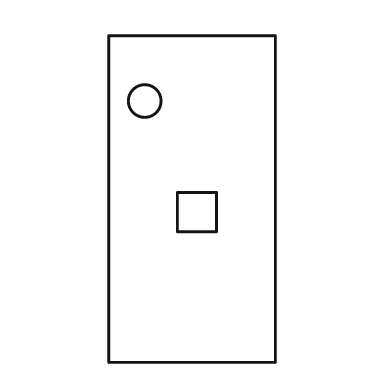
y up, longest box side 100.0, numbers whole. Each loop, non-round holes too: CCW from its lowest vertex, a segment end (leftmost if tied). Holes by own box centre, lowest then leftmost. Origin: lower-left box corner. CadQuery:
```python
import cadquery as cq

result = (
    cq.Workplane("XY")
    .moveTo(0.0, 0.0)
    .lineTo(51.0, 0.0)
    .lineTo(51.0, 100.0)
    .lineTo(0.0, 100.0)
    .close()
    .moveTo(21.0, 40.0)
    .lineTo(33.0, 40.0)
    .lineTo(33.0, 52.0)
    .lineTo(21.0, 52.0)
    .close()
    .moveTo(11.0, 80.0)
    .circle(5.0)
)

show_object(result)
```